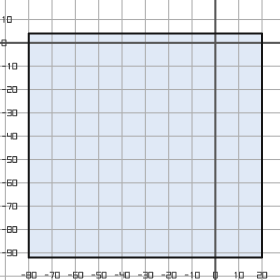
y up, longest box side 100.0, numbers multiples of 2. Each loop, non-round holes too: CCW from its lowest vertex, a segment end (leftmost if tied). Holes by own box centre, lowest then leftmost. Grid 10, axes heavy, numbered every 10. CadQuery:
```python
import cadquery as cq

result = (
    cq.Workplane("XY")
    .moveTo(-80.0, -92.0)
    .lineTo(20.0, -92.0)
    .lineTo(20.0, 4.0)
    .lineTo(-80.0, 4.0)
    .close()
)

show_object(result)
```